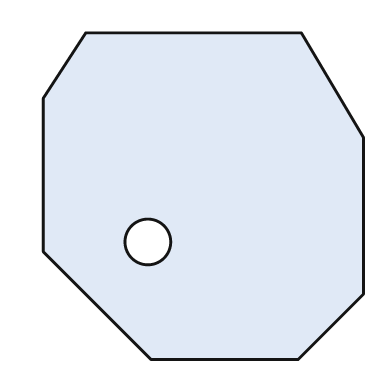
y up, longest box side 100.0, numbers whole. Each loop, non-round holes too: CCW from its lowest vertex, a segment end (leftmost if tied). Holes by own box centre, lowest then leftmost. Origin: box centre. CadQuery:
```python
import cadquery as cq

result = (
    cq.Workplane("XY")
    .moveTo(-16.0, -50.0)
    .lineTo(29.0, -50.0)
    .lineTo(49.0, -30.0)
    .lineTo(49.0, 18.0)
    .lineTo(30.0, 50.0)
    .lineTo(-36.0, 50.0)
    .lineTo(-49.0, 30.0)
    .lineTo(-49.0, -17.0)
    .close()
    .moveTo(-17.0, -14.0)
    .circle(7.0)
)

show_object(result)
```